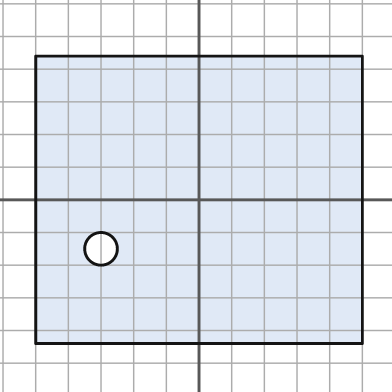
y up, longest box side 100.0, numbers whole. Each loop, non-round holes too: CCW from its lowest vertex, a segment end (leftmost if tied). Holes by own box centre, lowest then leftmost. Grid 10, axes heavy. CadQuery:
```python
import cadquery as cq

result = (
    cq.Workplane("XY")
    .moveTo(-50.0, -44.0)
    .lineTo(50.0, -44.0)
    .lineTo(50.0, 44.0)
    .lineTo(-50.0, 44.0)
    .close()
    .moveTo(-30.0, -15.0)
    .circle(5.0)
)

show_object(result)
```